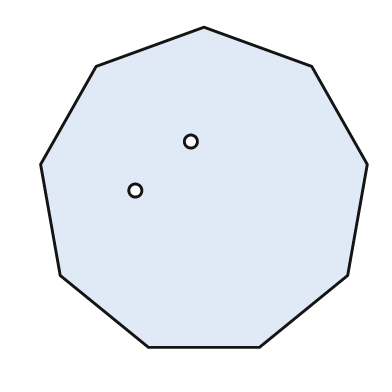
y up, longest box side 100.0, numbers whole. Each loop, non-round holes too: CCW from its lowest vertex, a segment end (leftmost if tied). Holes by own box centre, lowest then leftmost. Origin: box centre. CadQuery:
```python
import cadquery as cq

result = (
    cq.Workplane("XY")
    .moveTo(-17.0, -49.0)
    .lineTo(17.0, -49.0)
    .lineTo(44.0, -27.0)
    .lineTo(50.0, 7.0)
    .lineTo(33.0, 37.0)
    .lineTo(0.0, 49.0)
    .lineTo(-33.0, 37.0)
    .lineTo(-50.0, 7.0)
    .lineTo(-44.0, -27.0)
    .close()
    .moveTo(-21.0, -1.0)
    .circle(2.0)
    .moveTo(-4.0, 14.0)
    .circle(2.0)
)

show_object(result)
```